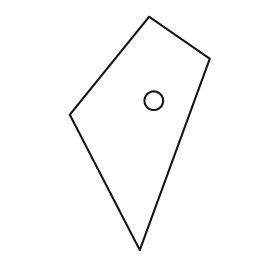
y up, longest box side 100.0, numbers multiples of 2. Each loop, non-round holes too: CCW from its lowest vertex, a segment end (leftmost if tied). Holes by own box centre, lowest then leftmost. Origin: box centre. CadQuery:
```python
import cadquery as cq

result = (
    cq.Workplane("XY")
    .moveTo(0.0, -50.0)
    .lineTo(30.0, 32.0)
    .lineTo(4.0, 50.0)
    .lineTo(-30.0, 8.0)
    .close()
    .moveTo(6.0, 14.0)
    .circle(4.0)
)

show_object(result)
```